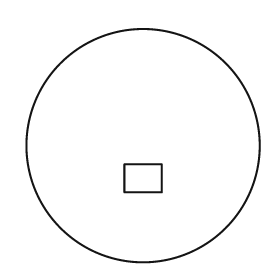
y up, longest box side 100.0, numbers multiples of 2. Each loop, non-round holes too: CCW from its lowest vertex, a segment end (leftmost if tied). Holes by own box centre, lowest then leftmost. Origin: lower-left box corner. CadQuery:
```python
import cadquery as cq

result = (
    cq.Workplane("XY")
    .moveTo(50.0, 50.0)
    .circle(50.0)
    .moveTo(42.0, 30.0)
    .lineTo(58.0, 30.0)
    .lineTo(58.0, 42.0)
    .lineTo(42.0, 42.0)
    .close()
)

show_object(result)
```